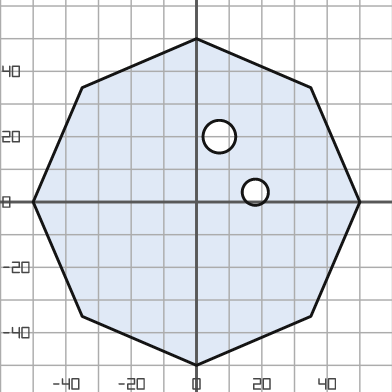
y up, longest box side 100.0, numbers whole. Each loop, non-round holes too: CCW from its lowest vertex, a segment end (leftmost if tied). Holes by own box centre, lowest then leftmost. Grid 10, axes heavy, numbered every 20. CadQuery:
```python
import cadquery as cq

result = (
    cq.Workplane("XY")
    .moveTo(0.0, -50.0)
    .lineTo(35.0, -35.0)
    .lineTo(50.0, 0.0)
    .lineTo(35.0, 35.0)
    .lineTo(0.0, 50.0)
    .lineTo(-35.0, 35.0)
    .lineTo(-50.0, 0.0)
    .lineTo(-35.0, -35.0)
    .close()
    .moveTo(18.0, 3.0)
    .circle(4.0)
    .moveTo(7.0, 20.0)
    .circle(5.0)
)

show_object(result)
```